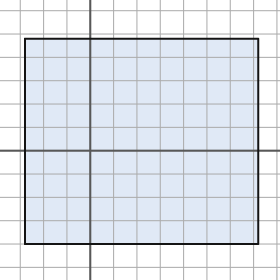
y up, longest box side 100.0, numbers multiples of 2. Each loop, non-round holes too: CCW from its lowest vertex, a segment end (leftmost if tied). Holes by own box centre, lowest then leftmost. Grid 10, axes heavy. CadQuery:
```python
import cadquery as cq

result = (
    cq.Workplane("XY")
    .moveTo(-28.0, -40.0)
    .lineTo(72.0, -40.0)
    .lineTo(72.0, 48.0)
    .lineTo(-28.0, 48.0)
    .close()
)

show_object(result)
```